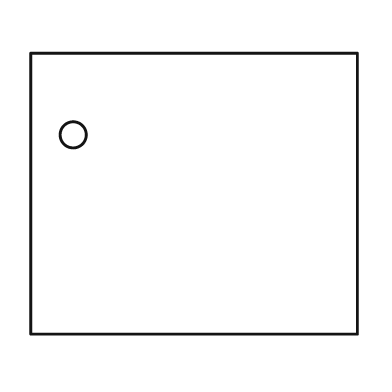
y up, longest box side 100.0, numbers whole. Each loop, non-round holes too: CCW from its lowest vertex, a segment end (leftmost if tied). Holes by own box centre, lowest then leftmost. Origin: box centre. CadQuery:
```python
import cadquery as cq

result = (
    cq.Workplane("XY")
    .moveTo(-50.0, -43.0)
    .lineTo(50.0, -43.0)
    .lineTo(50.0, 43.0)
    .lineTo(-50.0, 43.0)
    .close()
    .moveTo(-37.0, 18.0)
    .circle(4.0)
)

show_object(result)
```